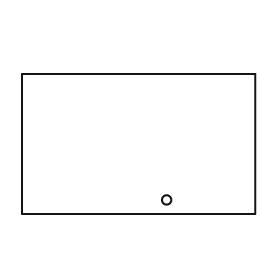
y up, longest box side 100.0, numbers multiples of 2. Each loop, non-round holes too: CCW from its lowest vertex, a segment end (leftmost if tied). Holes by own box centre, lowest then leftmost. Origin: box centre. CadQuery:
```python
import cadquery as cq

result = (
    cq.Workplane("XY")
    .moveTo(-50.0, -30.0)
    .lineTo(50.0, -30.0)
    .lineTo(50.0, 30.0)
    .lineTo(-50.0, 30.0)
    .close()
    .moveTo(12.0, -24.0)
    .circle(2.0)
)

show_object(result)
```